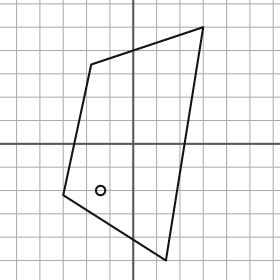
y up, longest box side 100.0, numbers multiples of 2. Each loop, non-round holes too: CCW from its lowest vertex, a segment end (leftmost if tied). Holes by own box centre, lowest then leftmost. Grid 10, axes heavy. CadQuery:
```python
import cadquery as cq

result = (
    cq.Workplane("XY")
    .moveTo(14.0, -50.0)
    .lineTo(30.0, 50.0)
    .lineTo(-18.0, 34.0)
    .lineTo(-30.0, -22.0)
    .close()
    .moveTo(-14.0, -20.0)
    .circle(2.0)
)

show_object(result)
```